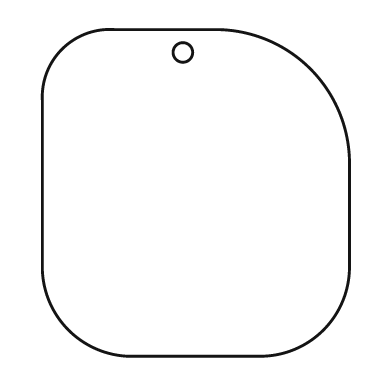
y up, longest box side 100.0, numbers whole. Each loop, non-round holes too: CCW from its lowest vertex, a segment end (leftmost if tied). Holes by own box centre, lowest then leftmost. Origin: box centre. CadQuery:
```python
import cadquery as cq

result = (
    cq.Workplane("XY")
    .moveTo(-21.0, -50.0)
    .lineTo(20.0, -50.0)
    .threePointArc((39.0, -42.0), (47.0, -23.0))
    .lineTo(47.0, 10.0)
    .threePointArc((35.0, 38.0), (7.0, 50.0))
    .lineTo(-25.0, 50.0)
    .threePointArc((-41.0, 44.0), (-47.0, 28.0))
    .lineTo(-47.0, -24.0)
    .threePointArc((-39.0, -42.0), (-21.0, -50.0))
    .close()
    .moveTo(-4.0, 43.0)
    .circle(3.0)
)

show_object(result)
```